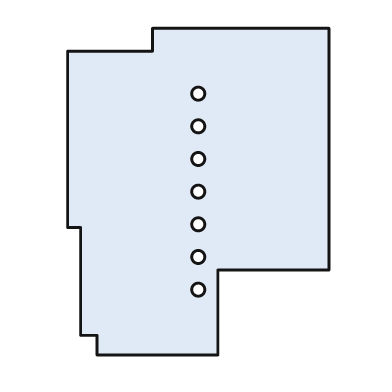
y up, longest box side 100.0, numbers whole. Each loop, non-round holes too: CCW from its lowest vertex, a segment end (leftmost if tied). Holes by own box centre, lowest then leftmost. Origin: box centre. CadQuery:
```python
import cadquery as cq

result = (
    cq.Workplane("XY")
    .moveTo(-31.0, -50.0)
    .lineTo(6.0, -50.0)
    .lineTo(6.0, -24.0)
    .lineTo(40.0, -24.0)
    .lineTo(40.0, 50.0)
    .lineTo(-14.0, 50.0)
    .lineTo(-14.0, 43.0)
    .lineTo(-40.0, 43.0)
    .lineTo(-40.0, -11.0)
    .lineTo(-36.0, -11.0)
    .lineTo(-36.0, -44.0)
    .lineTo(-31.0, -44.0)
    .close()
    .moveTo(0.0, -30.0)
    .circle(2.0)
    .moveTo(0.0, -20.0)
    .circle(2.0)
    .moveTo(0.0, -10.0)
    .circle(2.0)
    .moveTo(0.0, 0.0)
    .circle(2.0)
    .moveTo(0.0, 10.0)
    .circle(2.0)
    .moveTo(0.0, 20.0)
    .circle(2.0)
    .moveTo(0.0, 30.0)
    .circle(2.0)
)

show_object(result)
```